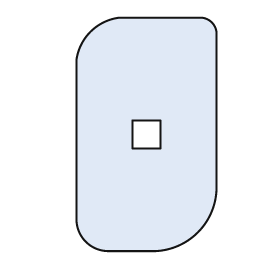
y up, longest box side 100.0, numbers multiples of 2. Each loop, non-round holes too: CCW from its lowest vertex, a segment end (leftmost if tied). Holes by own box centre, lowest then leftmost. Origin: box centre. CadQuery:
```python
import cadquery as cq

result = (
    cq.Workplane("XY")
    .moveTo(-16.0, -50.0)
    .lineTo(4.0, -50.0)
    .threePointArc((22.0, -42.0), (30.0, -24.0))
    .lineTo(30.0, 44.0)
    .threePointArc((28.0, 48.0), (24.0, 50.0))
    .lineTo(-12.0, 50.0)
    .threePointArc((-24.0, 44.0), (-30.0, 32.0))
    .lineTo(-30.0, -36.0)
    .threePointArc((-26.0, -46.0), (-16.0, -50.0))
    .close()
    .moveTo(-6.0, -6.0)
    .lineTo(6.0, -6.0)
    .lineTo(6.0, 6.0)
    .lineTo(-6.0, 6.0)
    .close()
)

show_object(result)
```